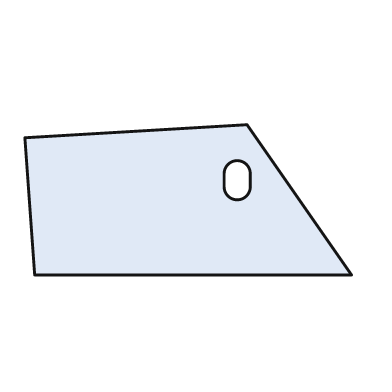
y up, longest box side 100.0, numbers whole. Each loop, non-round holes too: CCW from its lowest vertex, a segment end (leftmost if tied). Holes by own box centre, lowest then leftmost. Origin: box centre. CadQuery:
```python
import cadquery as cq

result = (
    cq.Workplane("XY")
    .moveTo(-47.0, -23.0)
    .lineTo(50.0, -23.0)
    .lineTo(18.0, 23.0)
    .lineTo(-50.0, 19.0)
    .close()
    .moveTo(11.0, 4.0)
    .threePointArc((15.0, 0.0), (19.0, 4.0))
    .lineTo(19.0, 8.0)
    .threePointArc((15.0, 12.0), (11.0, 8.0))
    .close()
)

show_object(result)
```